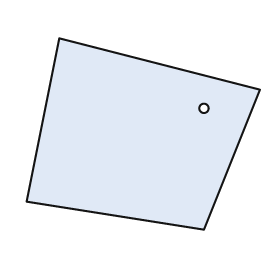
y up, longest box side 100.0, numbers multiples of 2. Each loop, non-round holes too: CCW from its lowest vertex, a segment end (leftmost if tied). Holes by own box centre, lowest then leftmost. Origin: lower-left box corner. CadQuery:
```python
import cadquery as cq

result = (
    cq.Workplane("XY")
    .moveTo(76.0, 0.0)
    .lineTo(100.0, 60.0)
    .lineTo(14.0, 82.0)
    .lineTo(0.0, 12.0)
    .close()
    .moveTo(76.0, 52.0)
    .circle(2.0)
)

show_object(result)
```